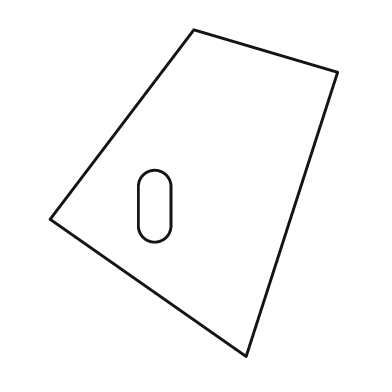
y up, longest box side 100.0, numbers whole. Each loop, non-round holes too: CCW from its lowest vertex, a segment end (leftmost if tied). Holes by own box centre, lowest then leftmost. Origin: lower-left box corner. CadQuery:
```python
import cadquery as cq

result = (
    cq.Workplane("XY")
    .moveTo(60.0, 0.0)
    .lineTo(88.0, 87.0)
    .lineTo(44.0, 100.0)
    .lineTo(0.0, 42.0)
    .close()
    .moveTo(27.0, 40.0)
    .threePointArc((32.0, 35.0), (37.0, 40.0))
    .lineTo(37.0, 52.0)
    .threePointArc((32.0, 57.0), (27.0, 52.0))
    .close()
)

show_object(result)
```